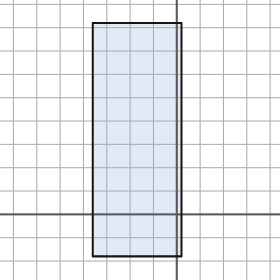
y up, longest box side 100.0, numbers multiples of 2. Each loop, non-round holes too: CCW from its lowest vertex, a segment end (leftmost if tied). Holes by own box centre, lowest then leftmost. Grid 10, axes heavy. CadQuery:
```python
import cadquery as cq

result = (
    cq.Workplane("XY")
    .moveTo(-36.0, -18.0)
    .lineTo(2.0, -18.0)
    .lineTo(2.0, 82.0)
    .lineTo(-36.0, 82.0)
    .close()
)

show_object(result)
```